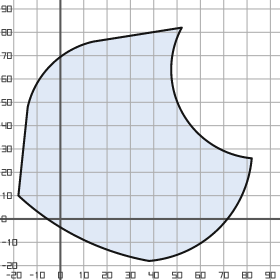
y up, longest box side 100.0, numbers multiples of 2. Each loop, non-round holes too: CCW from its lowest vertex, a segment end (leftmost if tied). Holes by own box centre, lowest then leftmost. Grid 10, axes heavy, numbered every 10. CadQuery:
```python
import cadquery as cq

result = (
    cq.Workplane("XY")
    .moveTo(38.0, -18.0)
    .threePointArc((68.0, -4.0), (82.0, 26.0))
    .threePointArc((52.0, 46.0), (52.0, 82.0))
    .lineTo(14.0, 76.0)
    .threePointArc((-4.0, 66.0), (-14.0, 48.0))
    .lineTo(-18.0, 10.0)
    .threePointArc((8.0, -8.0), (38.0, -18.0))
    .close()
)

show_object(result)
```